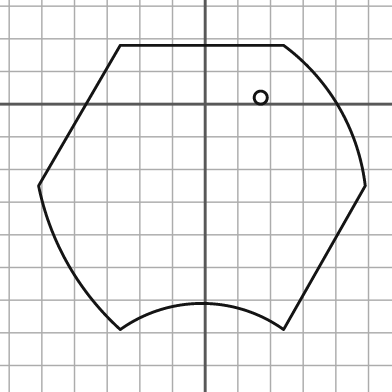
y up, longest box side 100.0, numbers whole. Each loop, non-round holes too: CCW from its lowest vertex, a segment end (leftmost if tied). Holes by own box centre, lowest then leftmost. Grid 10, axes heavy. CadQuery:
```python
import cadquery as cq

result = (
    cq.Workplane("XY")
    .moveTo(-26.0, -69.0)
    .threePointArc((-1.0, -61.0), (24.0, -69.0))
    .lineTo(49.0, -25.0)
    .threePointArc((41.0, -1.0), (24.0, 18.0))
    .lineTo(-26.0, 18.0)
    .lineTo(-51.0, -25.0)
    .threePointArc((-42.0, -49.0), (-26.0, -69.0))
    .close()
    .moveTo(17.0, 2.0)
    .circle(2.0)
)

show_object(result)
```